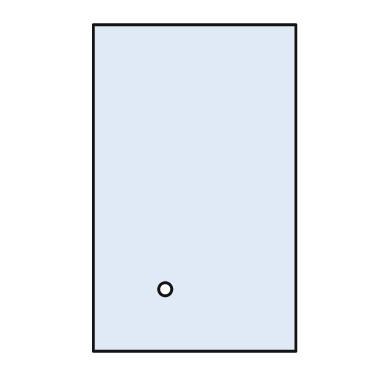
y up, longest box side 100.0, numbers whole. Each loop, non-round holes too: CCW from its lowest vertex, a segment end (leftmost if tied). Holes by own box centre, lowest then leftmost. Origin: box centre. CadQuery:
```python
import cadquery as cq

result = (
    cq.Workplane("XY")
    .moveTo(-31.0, -50.0)
    .lineTo(31.0, -50.0)
    .lineTo(31.0, 50.0)
    .lineTo(-31.0, 50.0)
    .close()
    .moveTo(-9.0, -31.0)
    .circle(2.0)
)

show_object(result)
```